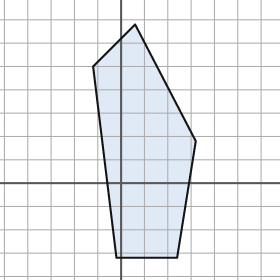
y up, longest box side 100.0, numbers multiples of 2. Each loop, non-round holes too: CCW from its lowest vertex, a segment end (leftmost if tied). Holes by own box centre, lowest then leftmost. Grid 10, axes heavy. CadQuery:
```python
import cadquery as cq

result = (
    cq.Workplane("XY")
    .moveTo(-2.0, -32.0)
    .lineTo(24.0, -32.0)
    .lineTo(32.0, 18.0)
    .lineTo(6.0, 68.0)
    .lineTo(-12.0, 50.0)
    .close()
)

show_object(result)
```